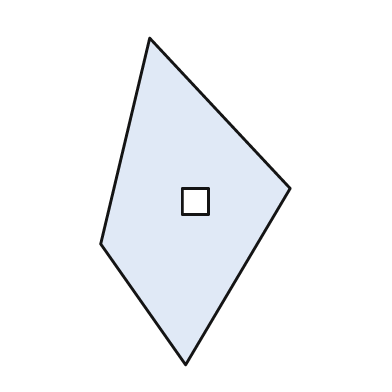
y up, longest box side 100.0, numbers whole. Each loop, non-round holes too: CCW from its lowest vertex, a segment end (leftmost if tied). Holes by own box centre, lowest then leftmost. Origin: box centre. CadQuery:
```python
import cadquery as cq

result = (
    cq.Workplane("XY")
    .moveTo(-3.0, -50.0)
    .lineTo(29.0, 4.0)
    .lineTo(-14.0, 50.0)
    .lineTo(-29.0, -13.0)
    .close()
    .moveTo(-4.0, -4.0)
    .lineTo(4.0, -4.0)
    .lineTo(4.0, 4.0)
    .lineTo(-4.0, 4.0)
    .close()
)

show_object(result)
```